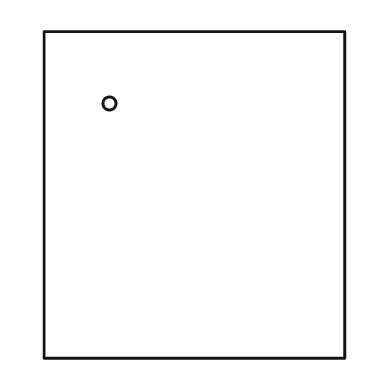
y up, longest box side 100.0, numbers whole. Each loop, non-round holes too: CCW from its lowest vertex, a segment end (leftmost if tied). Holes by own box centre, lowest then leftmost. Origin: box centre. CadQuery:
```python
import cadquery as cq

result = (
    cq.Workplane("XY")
    .moveTo(-46.0, -50.0)
    .lineTo(46.0, -50.0)
    .lineTo(46.0, 50.0)
    .lineTo(-46.0, 50.0)
    .close()
    .moveTo(-26.0, 28.0)
    .circle(2.0)
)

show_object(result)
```